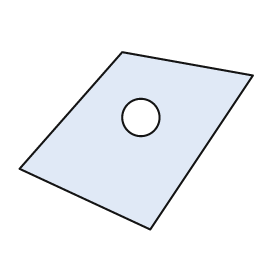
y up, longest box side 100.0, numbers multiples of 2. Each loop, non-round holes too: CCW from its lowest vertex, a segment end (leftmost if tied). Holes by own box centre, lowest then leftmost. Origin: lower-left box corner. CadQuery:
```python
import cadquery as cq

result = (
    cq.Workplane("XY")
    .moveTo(56.0, 0.0)
    .lineTo(100.0, 66.0)
    .lineTo(44.0, 76.0)
    .lineTo(0.0, 26.0)
    .close()
    .moveTo(52.0, 48.0)
    .circle(8.0)
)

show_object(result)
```